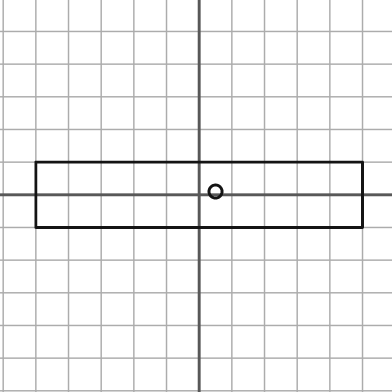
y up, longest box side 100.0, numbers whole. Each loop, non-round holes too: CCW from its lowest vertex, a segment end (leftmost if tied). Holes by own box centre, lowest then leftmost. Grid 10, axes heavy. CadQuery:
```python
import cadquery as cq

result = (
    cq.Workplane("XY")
    .moveTo(-50.0, -10.0)
    .lineTo(50.0, -10.0)
    .lineTo(50.0, 10.0)
    .lineTo(-50.0, 10.0)
    .close()
    .moveTo(5.0, 1.0)
    .circle(2.0)
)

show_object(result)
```